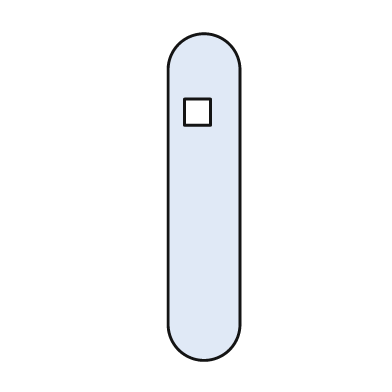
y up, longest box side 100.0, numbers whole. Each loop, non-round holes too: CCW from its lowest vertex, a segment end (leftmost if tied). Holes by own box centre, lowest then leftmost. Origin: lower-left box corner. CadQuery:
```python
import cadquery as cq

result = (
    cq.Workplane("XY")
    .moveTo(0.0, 11.0)
    .threePointArc((11.0, 0.0), (22.0, 11.0))
    .lineTo(22.0, 89.0)
    .threePointArc((11.0, 100.0), (0.0, 89.0))
    .close()
    .moveTo(5.0, 72.0)
    .lineTo(13.0, 72.0)
    .lineTo(13.0, 80.0)
    .lineTo(5.0, 80.0)
    .close()
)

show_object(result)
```